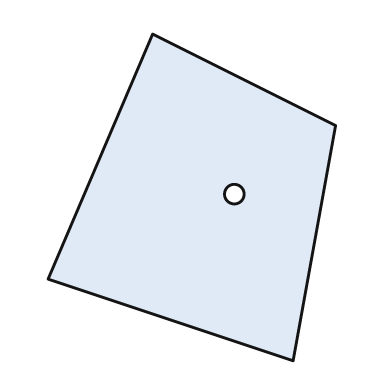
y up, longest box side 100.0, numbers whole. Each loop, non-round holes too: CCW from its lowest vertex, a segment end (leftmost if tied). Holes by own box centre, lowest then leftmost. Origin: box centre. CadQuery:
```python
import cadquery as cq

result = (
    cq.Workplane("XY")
    .moveTo(31.0, -50.0)
    .lineTo(44.0, 22.0)
    .lineTo(-12.0, 50.0)
    .lineTo(-44.0, -25.0)
    .close()
    .moveTo(13.0, 1.0)
    .circle(3.0)
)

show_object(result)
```